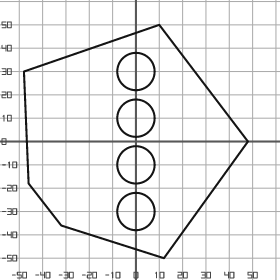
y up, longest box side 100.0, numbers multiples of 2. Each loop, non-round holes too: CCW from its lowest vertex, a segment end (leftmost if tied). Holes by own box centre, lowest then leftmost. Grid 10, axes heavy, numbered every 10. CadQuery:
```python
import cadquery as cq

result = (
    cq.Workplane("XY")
    .moveTo(12.0, -50.0)
    .lineTo(48.0, 0.0)
    .lineTo(10.0, 50.0)
    .lineTo(-48.0, 30.0)
    .lineTo(-46.0, -18.0)
    .lineTo(-32.0, -36.0)
    .close()
    .moveTo(0.0, -30.0)
    .circle(8.0)
    .moveTo(0.0, -10.0)
    .circle(8.0)
    .moveTo(0.0, 10.0)
    .circle(8.0)
    .moveTo(0.0, 30.0)
    .circle(8.0)
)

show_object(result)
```